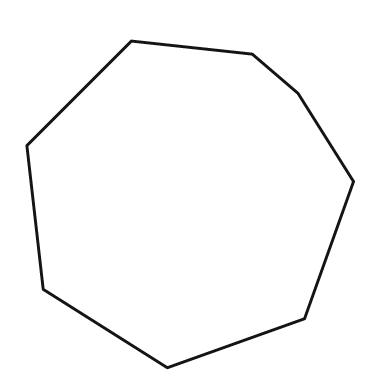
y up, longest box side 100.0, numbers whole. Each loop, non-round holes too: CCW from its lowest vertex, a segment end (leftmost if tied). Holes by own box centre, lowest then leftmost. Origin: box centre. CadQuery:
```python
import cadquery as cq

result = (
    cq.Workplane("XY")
    .moveTo(-7.0, -50.0)
    .lineTo(35.0, -35.0)
    .lineTo(50.0, 7.0)
    .lineTo(33.0, 34.0)
    .lineTo(19.0, 46.0)
    .lineTo(-18.0, 50.0)
    .lineTo(-50.0, 18.0)
    .lineTo(-45.0, -26.0)
    .close()
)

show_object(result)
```